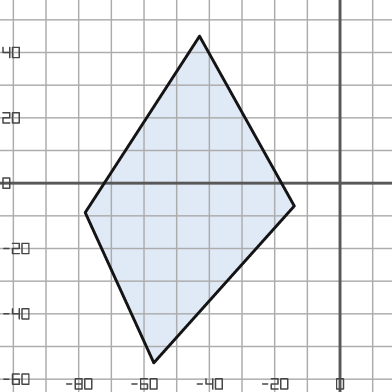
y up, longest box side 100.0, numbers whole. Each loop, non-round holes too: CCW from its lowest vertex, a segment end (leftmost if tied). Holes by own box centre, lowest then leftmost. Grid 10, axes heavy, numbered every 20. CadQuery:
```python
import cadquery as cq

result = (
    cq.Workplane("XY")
    .moveTo(-57.0, -55.0)
    .lineTo(-14.0, -7.0)
    .lineTo(-43.0, 45.0)
    .lineTo(-78.0, -9.0)
    .close()
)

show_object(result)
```